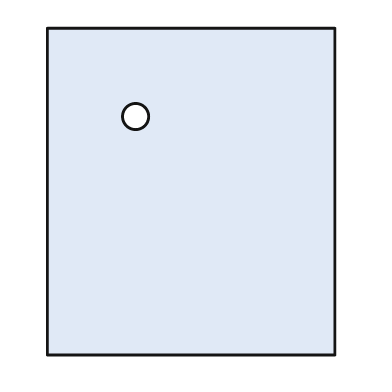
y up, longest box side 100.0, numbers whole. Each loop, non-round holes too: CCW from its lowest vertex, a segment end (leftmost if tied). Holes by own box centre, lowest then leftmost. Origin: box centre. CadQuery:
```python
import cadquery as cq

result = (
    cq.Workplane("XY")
    .moveTo(-44.0, -50.0)
    .lineTo(44.0, -50.0)
    .lineTo(44.0, 50.0)
    .lineTo(-44.0, 50.0)
    .close()
    .moveTo(-17.0, 23.0)
    .circle(4.0)
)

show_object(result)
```